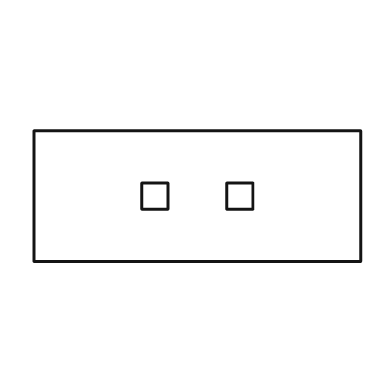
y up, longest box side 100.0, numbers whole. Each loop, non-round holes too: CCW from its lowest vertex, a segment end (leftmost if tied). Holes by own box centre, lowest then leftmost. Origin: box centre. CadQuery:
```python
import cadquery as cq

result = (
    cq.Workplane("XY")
    .moveTo(-50.0, -20.0)
    .lineTo(50.0, -20.0)
    .lineTo(50.0, 20.0)
    .lineTo(-50.0, 20.0)
    .close()
    .moveTo(-17.0, -4.0)
    .lineTo(-9.0, -4.0)
    .lineTo(-9.0, 4.0)
    .lineTo(-17.0, 4.0)
    .close()
    .moveTo(9.0, -4.0)
    .lineTo(17.0, -4.0)
    .lineTo(17.0, 4.0)
    .lineTo(9.0, 4.0)
    .close()
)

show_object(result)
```